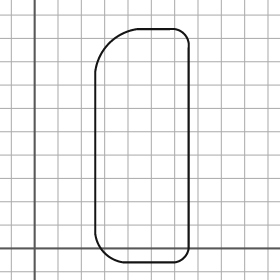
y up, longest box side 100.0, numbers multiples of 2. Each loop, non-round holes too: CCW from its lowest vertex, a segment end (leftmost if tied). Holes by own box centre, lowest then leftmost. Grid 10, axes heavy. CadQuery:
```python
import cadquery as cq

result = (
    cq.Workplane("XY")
    .moveTo(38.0, -6.0)
    .lineTo(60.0, -6.0)
    .threePointArc((64.0, -4.0), (66.0, 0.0))
    .lineTo(66.0, 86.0)
    .threePointArc((64.0, 92.0), (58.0, 94.0))
    .lineTo(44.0, 94.0)
    .threePointArc((32.0, 88.0), (26.0, 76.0))
    .lineTo(26.0, 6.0)
    .threePointArc((30.0, -2.0), (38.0, -6.0))
    .close()
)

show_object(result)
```